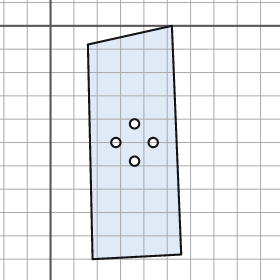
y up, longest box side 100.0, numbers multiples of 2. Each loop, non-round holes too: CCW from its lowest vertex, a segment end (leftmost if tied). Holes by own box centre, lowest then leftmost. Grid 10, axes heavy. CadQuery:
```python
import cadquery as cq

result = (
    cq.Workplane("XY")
    .moveTo(18.0, -100.0)
    .lineTo(56.0, -98.0)
    .lineTo(52.0, 0.0)
    .lineTo(16.0, -8.0)
    .close()
    .moveTo(36.0, -58.0)
    .circle(2.0)
    .moveTo(28.0, -50.0)
    .circle(2.0)
    .moveTo(44.0, -50.0)
    .circle(2.0)
    .moveTo(36.0, -42.0)
    .circle(2.0)
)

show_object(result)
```